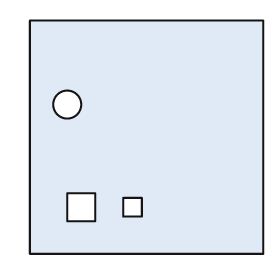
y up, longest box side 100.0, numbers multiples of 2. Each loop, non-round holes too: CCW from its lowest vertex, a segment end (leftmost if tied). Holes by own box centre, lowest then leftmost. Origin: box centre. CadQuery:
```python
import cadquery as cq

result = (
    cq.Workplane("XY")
    .moveTo(-50.0, -50.0)
    .lineTo(50.0, -50.0)
    .lineTo(50.0, 50.0)
    .lineTo(-50.0, 50.0)
    .close()
    .moveTo(-34.0, -36.0)
    .lineTo(-22.0, -36.0)
    .lineTo(-22.0, -24.0)
    .lineTo(-34.0, -24.0)
    .close()
    .moveTo(-10.0, -34.0)
    .lineTo(-2.0, -34.0)
    .lineTo(-2.0, -26.0)
    .lineTo(-10.0, -26.0)
    .close()
    .moveTo(-34.0, 14.0)
    .circle(6.0)
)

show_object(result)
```